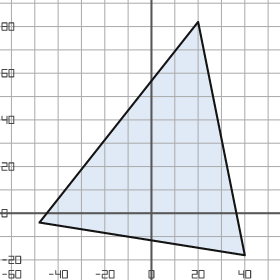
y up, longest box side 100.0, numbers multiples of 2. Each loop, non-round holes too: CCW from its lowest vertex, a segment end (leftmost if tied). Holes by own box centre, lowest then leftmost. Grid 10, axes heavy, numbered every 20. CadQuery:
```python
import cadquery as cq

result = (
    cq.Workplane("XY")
    .moveTo(40.0, -18.0)
    .lineTo(20.0, 82.0)
    .lineTo(-48.0, -4.0)
    .close()
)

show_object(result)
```